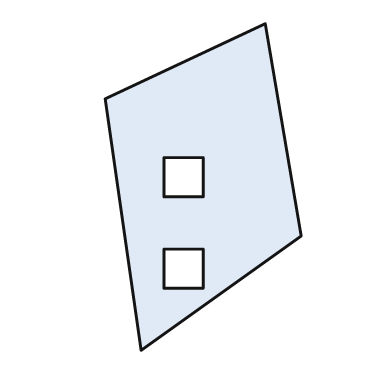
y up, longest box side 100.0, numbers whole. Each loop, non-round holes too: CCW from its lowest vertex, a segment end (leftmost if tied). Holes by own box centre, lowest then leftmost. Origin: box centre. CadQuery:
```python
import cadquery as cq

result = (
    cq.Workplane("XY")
    .moveTo(-19.0, -50.0)
    .lineTo(30.0, -15.0)
    .lineTo(19.0, 50.0)
    .lineTo(-30.0, 27.0)
    .close()
    .moveTo(-12.0, -31.0)
    .lineTo(0.0, -31.0)
    .lineTo(0.0, -19.0)
    .lineTo(-12.0, -19.0)
    .close()
    .moveTo(-12.0, -3.0)
    .lineTo(0.0, -3.0)
    .lineTo(0.0, 9.0)
    .lineTo(-12.0, 9.0)
    .close()
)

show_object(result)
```